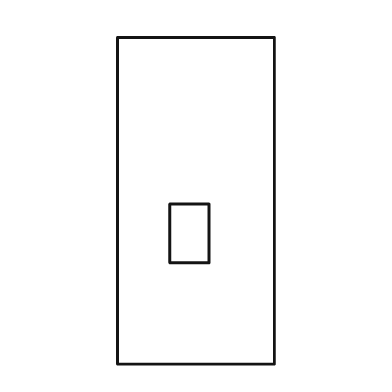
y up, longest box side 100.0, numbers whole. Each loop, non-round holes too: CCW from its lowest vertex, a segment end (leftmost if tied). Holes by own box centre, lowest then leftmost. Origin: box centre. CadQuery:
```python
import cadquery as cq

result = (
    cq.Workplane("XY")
    .moveTo(-24.0, -50.0)
    .lineTo(24.0, -50.0)
    .lineTo(24.0, 50.0)
    .lineTo(-24.0, 50.0)
    .close()
    .moveTo(-8.0, -19.0)
    .lineTo(4.0, -19.0)
    .lineTo(4.0, -1.0)
    .lineTo(-8.0, -1.0)
    .close()
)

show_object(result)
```